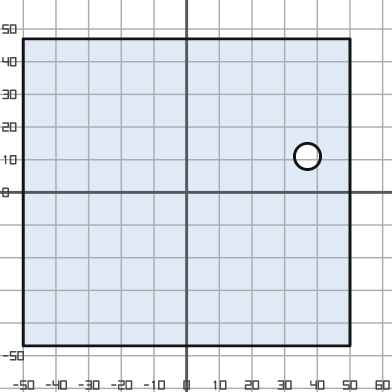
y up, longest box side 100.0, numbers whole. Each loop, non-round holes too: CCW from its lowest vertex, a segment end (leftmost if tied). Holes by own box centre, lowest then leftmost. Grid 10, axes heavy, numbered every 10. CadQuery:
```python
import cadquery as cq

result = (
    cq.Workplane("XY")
    .moveTo(-50.0, -47.0)
    .lineTo(50.0, -47.0)
    .lineTo(50.0, 47.0)
    .lineTo(-50.0, 47.0)
    .close()
    .moveTo(37.0, 11.0)
    .circle(4.0)
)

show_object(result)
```